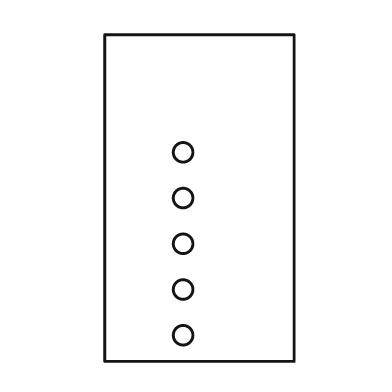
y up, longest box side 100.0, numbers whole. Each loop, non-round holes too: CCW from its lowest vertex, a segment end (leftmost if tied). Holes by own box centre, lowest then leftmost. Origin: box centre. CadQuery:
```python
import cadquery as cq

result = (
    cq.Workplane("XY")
    .moveTo(-29.0, -50.0)
    .lineTo(29.0, -50.0)
    .lineTo(29.0, 50.0)
    .lineTo(-29.0, 50.0)
    .close()
    .moveTo(-5.0, -42.0)
    .circle(3.0)
    .moveTo(-5.0, -28.0)
    .circle(3.0)
    .moveTo(-5.0, -14.0)
    .circle(3.0)
    .moveTo(-5.0, 0.0)
    .circle(3.0)
    .moveTo(-5.0, 14.0)
    .circle(3.0)
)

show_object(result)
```